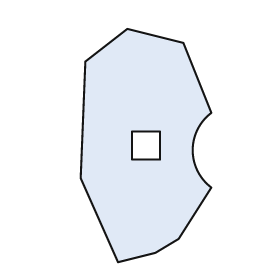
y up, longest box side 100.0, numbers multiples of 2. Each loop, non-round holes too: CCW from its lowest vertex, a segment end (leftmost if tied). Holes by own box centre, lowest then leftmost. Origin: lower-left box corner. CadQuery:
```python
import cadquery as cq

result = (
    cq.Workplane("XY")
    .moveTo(16.0, 0.0)
    .lineTo(32.0, 4.0)
    .lineTo(42.0, 10.0)
    .lineTo(56.0, 32.0)
    .threePointArc((48.0, 48.0), (56.0, 64.0))
    .lineTo(44.0, 94.0)
    .lineTo(20.0, 100.0)
    .lineTo(2.0, 86.0)
    .lineTo(0.0, 36.0)
    .close()
    .moveTo(22.0, 44.0)
    .lineTo(34.0, 44.0)
    .lineTo(34.0, 56.0)
    .lineTo(22.0, 56.0)
    .close()
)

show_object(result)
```